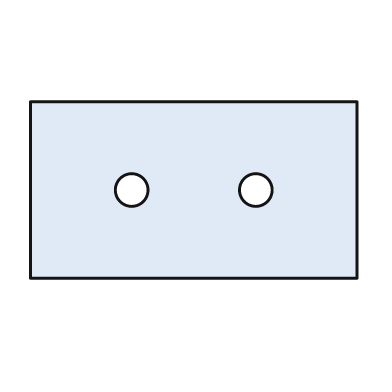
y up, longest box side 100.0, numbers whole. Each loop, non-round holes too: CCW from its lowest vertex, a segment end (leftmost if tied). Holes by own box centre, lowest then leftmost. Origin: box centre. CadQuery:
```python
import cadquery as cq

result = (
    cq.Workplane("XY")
    .moveTo(-50.0, -27.0)
    .lineTo(50.0, -27.0)
    .lineTo(50.0, 27.0)
    .lineTo(-50.0, 27.0)
    .close()
    .moveTo(-19.0, 0.0)
    .circle(5.0)
    .moveTo(19.0, 0.0)
    .circle(5.0)
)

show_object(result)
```